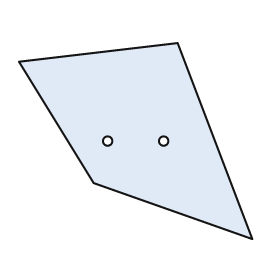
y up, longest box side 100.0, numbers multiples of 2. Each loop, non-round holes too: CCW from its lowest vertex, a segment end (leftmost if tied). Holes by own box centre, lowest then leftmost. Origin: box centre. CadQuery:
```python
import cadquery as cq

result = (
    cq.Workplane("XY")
    .moveTo(50.0, -42.0)
    .lineTo(18.0, 42.0)
    .lineTo(-50.0, 34.0)
    .lineTo(-18.0, -18.0)
    .close()
    .moveTo(-12.0, 0.0)
    .circle(2.0)
    .moveTo(12.0, 0.0)
    .circle(2.0)
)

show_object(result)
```